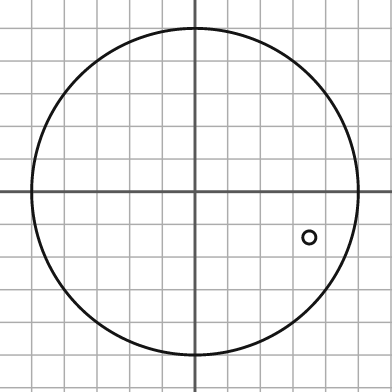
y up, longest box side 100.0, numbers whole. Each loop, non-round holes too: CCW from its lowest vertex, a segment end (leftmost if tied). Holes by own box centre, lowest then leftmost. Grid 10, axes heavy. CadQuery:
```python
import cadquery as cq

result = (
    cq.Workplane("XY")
    .moveTo(0.0, 0.0)
    .circle(50.0)
    .moveTo(35.0, -14.0)
    .circle(2.0)
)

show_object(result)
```